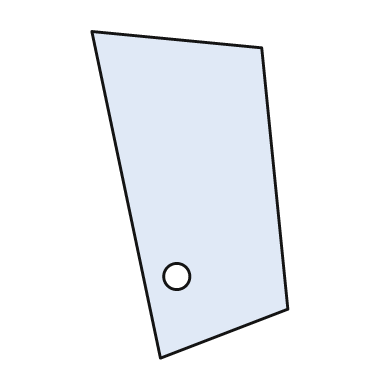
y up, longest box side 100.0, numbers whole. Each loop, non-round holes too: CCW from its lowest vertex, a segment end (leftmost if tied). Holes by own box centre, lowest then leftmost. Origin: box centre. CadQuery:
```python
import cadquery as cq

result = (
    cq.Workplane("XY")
    .moveTo(-9.0, -50.0)
    .lineTo(30.0, -35.0)
    .lineTo(22.0, 45.0)
    .lineTo(-30.0, 50.0)
    .close()
    .moveTo(-4.0, -25.0)
    .circle(4.0)
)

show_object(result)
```